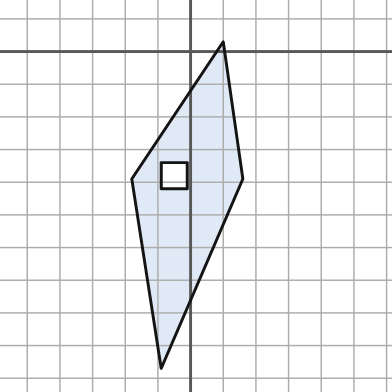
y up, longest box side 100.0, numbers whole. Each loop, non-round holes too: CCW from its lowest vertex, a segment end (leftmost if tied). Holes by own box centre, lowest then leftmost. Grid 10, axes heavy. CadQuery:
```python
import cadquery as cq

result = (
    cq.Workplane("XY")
    .moveTo(-9.0, -97.0)
    .lineTo(16.0, -39.0)
    .lineTo(10.0, 3.0)
    .lineTo(-18.0, -39.0)
    .close()
    .moveTo(-9.0, -42.0)
    .lineTo(-1.0, -42.0)
    .lineTo(-1.0, -34.0)
    .lineTo(-9.0, -34.0)
    .close()
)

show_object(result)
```